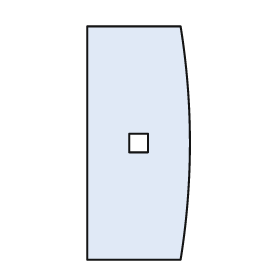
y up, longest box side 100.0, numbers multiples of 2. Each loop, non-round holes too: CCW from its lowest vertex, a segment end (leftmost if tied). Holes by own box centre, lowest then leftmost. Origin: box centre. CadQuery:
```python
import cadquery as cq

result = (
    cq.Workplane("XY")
    .moveTo(-22.0, -50.0)
    .lineTo(18.0, -50.0)
    .threePointArc((22.0, 0.0), (18.0, 50.0))
    .lineTo(-22.0, 50.0)
    .close()
    .moveTo(-4.0, -4.0)
    .lineTo(4.0, -4.0)
    .lineTo(4.0, 4.0)
    .lineTo(-4.0, 4.0)
    .close()
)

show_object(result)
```